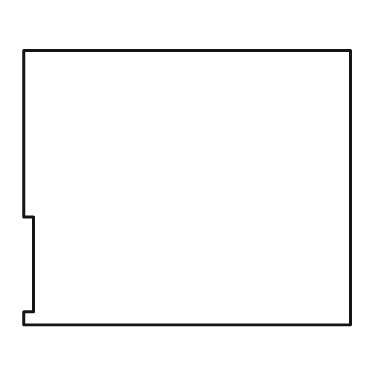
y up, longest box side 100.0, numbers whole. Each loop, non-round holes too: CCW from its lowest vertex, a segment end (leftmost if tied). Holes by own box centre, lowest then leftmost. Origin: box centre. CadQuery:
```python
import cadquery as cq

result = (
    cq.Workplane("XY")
    .moveTo(-50.0, -42.0)
    .lineTo(50.0, -42.0)
    .lineTo(50.0, 42.0)
    .lineTo(-50.0, 42.0)
    .lineTo(-50.0, -9.0)
    .lineTo(-47.0, -9.0)
    .lineTo(-47.0, -38.0)
    .lineTo(-50.0, -38.0)
    .close()
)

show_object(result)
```